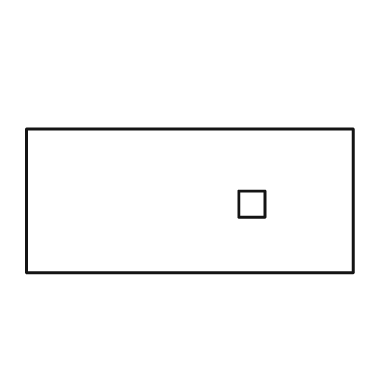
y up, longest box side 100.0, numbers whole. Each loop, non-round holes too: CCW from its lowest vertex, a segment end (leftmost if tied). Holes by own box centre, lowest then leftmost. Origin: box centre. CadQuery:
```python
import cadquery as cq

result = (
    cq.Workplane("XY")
    .moveTo(-50.0, -22.0)
    .lineTo(50.0, -22.0)
    .lineTo(50.0, 22.0)
    .lineTo(-50.0, 22.0)
    .close()
    .moveTo(15.0, -5.0)
    .lineTo(23.0, -5.0)
    .lineTo(23.0, 3.0)
    .lineTo(15.0, 3.0)
    .close()
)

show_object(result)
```